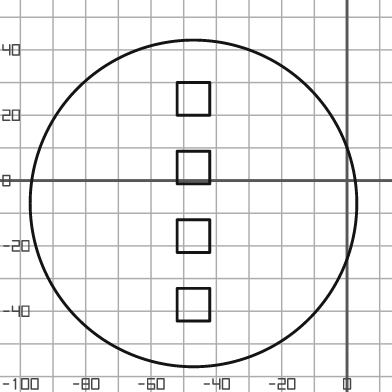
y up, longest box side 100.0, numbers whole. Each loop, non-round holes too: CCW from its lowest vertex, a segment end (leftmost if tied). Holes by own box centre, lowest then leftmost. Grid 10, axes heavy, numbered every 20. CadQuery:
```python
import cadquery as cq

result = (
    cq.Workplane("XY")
    .moveTo(-47.0, -7.0)
    .circle(50.0)
    .moveTo(-52.0, -43.0)
    .lineTo(-42.0, -43.0)
    .lineTo(-42.0, -33.0)
    .lineTo(-52.0, -33.0)
    .close()
    .moveTo(-52.0, -22.0)
    .lineTo(-42.0, -22.0)
    .lineTo(-42.0, -12.0)
    .lineTo(-52.0, -12.0)
    .close()
    .moveTo(-52.0, -1.0)
    .lineTo(-42.0, -1.0)
    .lineTo(-42.0, 9.0)
    .lineTo(-52.0, 9.0)
    .close()
    .moveTo(-52.0, 20.0)
    .lineTo(-42.0, 20.0)
    .lineTo(-42.0, 30.0)
    .lineTo(-52.0, 30.0)
    .close()
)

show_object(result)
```